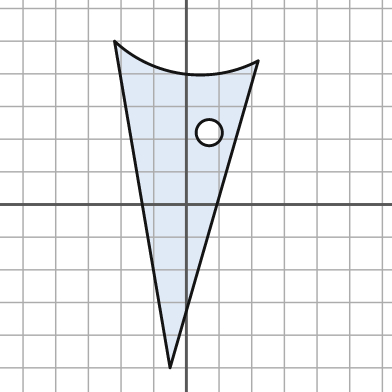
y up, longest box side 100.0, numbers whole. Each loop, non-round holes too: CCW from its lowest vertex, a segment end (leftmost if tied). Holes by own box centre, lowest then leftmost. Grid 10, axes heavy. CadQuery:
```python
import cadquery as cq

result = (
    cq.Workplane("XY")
    .moveTo(-5.0, -50.0)
    .lineTo(22.0, 44.0)
    .threePointArc((-1.0, 40.0), (-22.0, 50.0))
    .close()
    .moveTo(7.0, 22.0)
    .circle(4.0)
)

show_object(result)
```